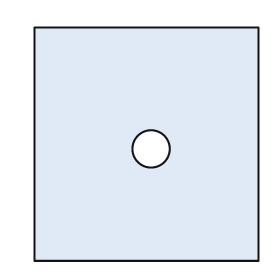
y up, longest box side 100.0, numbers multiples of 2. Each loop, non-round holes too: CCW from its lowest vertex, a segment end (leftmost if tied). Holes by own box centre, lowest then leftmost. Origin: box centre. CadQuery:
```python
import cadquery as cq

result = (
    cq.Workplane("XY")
    .moveTo(-48.0, -50.0)
    .lineTo(48.0, -50.0)
    .lineTo(48.0, 50.0)
    .lineTo(-48.0, 50.0)
    .close()
    .moveTo(2.0, -2.0)
    .circle(8.0)
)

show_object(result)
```